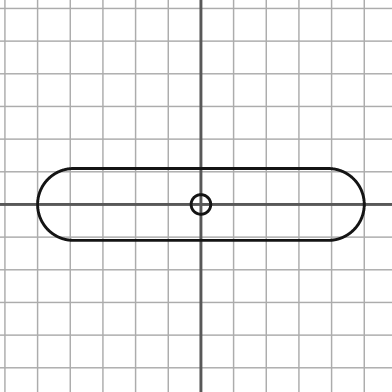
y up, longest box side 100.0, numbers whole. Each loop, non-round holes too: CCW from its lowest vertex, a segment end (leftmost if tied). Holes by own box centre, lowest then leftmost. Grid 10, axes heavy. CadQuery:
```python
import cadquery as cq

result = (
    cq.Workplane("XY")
    .moveTo(-39.0, -11.0)
    .lineTo(39.0, -11.0)
    .threePointArc((50.0, 0.0), (39.0, 11.0))
    .lineTo(-39.0, 11.0)
    .threePointArc((-50.0, 0.0), (-39.0, -11.0))
    .close()
    .moveTo(0.0, 0.0)
    .circle(3.0)
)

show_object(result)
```